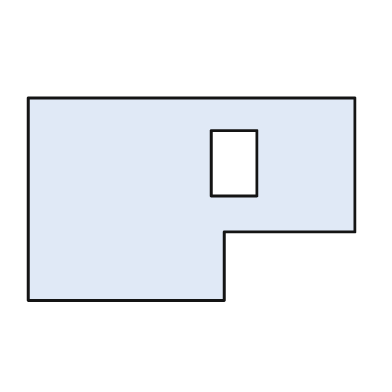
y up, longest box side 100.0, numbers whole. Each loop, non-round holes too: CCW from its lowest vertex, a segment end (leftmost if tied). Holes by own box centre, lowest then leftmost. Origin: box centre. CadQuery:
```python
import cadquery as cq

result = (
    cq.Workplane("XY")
    .moveTo(-50.0, -31.0)
    .lineTo(10.0, -31.0)
    .lineTo(10.0, -10.0)
    .lineTo(50.0, -10.0)
    .lineTo(50.0, 31.0)
    .lineTo(-50.0, 31.0)
    .close()
    .moveTo(6.0, 1.0)
    .lineTo(20.0, 1.0)
    .lineTo(20.0, 21.0)
    .lineTo(6.0, 21.0)
    .close()
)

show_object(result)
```